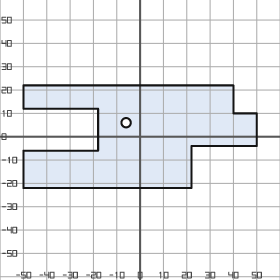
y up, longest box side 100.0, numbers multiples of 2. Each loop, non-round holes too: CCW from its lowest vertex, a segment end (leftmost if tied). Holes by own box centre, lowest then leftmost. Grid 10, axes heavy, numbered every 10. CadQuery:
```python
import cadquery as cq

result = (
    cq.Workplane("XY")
    .moveTo(-50.0, -22.0)
    .lineTo(22.0, -22.0)
    .lineTo(22.0, -4.0)
    .lineTo(50.0, -4.0)
    .lineTo(50.0, 10.0)
    .lineTo(40.0, 10.0)
    .lineTo(40.0, 22.0)
    .lineTo(-50.0, 22.0)
    .lineTo(-50.0, 12.0)
    .lineTo(-18.0, 12.0)
    .lineTo(-18.0, -6.0)
    .lineTo(-50.0, -6.0)
    .close()
    .moveTo(-6.0, 6.0)
    .circle(2.0)
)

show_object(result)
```